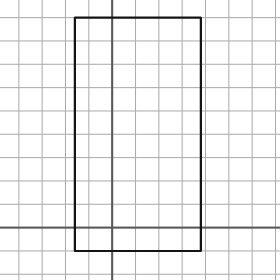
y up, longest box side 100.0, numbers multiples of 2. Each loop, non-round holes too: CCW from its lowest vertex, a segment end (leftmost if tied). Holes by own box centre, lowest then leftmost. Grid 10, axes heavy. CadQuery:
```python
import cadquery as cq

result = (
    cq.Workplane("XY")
    .moveTo(-16.0, -10.0)
    .lineTo(38.0, -10.0)
    .lineTo(38.0, 90.0)
    .lineTo(-16.0, 90.0)
    .close()
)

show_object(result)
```